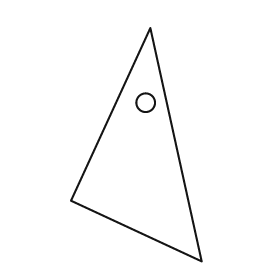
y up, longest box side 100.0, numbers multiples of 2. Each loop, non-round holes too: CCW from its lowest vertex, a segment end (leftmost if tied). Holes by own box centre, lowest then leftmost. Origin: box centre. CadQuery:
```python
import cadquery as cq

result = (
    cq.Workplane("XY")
    .moveTo(28.0, -50.0)
    .lineTo(6.0, 50.0)
    .lineTo(-28.0, -24.0)
    .close()
    .moveTo(4.0, 18.0)
    .circle(4.0)
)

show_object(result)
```